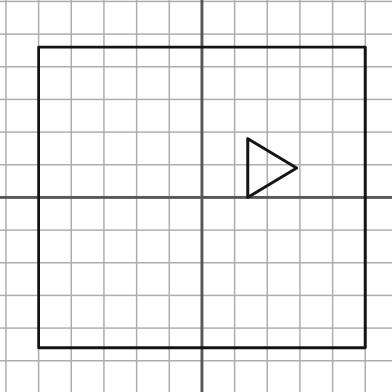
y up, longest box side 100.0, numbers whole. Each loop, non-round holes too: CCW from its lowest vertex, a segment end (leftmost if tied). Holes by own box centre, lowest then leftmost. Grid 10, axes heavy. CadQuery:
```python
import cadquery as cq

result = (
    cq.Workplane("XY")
    .moveTo(-50.0, -46.0)
    .lineTo(50.0, -46.0)
    .lineTo(50.0, 46.0)
    .lineTo(-50.0, 46.0)
    .close()
    .moveTo(14.0, 0.0)
    .lineTo(29.0, 9.0)
    .lineTo(14.0, 18.0)
    .close()
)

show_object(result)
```